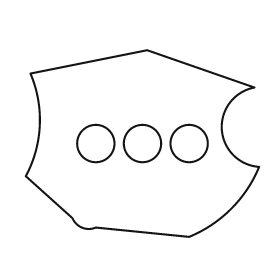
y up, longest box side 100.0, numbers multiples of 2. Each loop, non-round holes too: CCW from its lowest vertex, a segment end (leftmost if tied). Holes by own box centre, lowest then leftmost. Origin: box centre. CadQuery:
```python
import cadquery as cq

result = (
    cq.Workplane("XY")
    .moveTo(20.0, -40.0)
    .threePointArc((38.0, -28.0), (50.0, -10.0))
    .threePointArc((34.0, 6.0), (48.0, 24.0))
    .lineTo(2.0, 40.0)
    .lineTo(-48.0, 30.0)
    .threePointArc((-44.0, 8.0), (-50.0, -14.0))
    .lineTo(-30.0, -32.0)
    .threePointArc((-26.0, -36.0), (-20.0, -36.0))
    .close()
    .moveTo(-20.0, 0.0)
    .circle(8.0)
    .moveTo(0.0, 0.0)
    .circle(8.0)
    .moveTo(20.0, 0.0)
    .circle(8.0)
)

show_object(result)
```